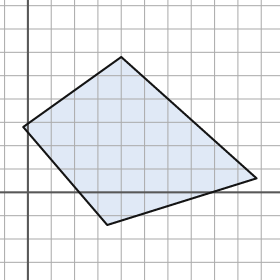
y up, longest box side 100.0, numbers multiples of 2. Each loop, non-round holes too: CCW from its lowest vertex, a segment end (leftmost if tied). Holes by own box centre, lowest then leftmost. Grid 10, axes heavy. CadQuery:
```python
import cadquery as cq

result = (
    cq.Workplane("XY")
    .moveTo(34.0, -14.0)
    .lineTo(98.0, 6.0)
    .lineTo(40.0, 58.0)
    .lineTo(-2.0, 28.0)
    .close()
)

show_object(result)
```